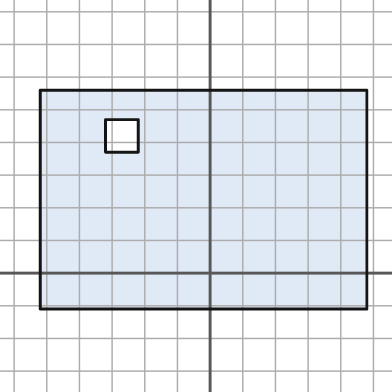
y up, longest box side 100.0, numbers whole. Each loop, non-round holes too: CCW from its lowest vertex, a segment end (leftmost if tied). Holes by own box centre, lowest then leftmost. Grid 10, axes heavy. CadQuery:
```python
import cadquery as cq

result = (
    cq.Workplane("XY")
    .moveTo(-52.0, -11.0)
    .lineTo(48.0, -11.0)
    .lineTo(48.0, 56.0)
    .lineTo(-52.0, 56.0)
    .close()
    .moveTo(-32.0, 37.0)
    .lineTo(-22.0, 37.0)
    .lineTo(-22.0, 47.0)
    .lineTo(-32.0, 47.0)
    .close()
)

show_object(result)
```